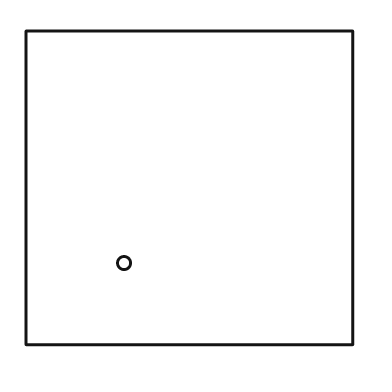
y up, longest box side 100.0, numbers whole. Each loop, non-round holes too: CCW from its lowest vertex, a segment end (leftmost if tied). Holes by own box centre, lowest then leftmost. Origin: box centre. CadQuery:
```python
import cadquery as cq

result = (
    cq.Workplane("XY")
    .moveTo(-50.0, -48.0)
    .lineTo(50.0, -48.0)
    .lineTo(50.0, 48.0)
    .lineTo(-50.0, 48.0)
    .close()
    .moveTo(-20.0, -23.0)
    .circle(2.0)
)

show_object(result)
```